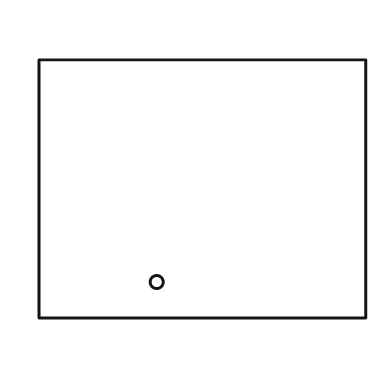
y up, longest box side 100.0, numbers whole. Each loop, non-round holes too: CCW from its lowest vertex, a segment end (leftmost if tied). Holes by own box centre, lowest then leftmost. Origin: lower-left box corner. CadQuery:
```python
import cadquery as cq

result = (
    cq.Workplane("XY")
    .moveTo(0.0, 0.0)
    .lineTo(100.0, 0.0)
    .lineTo(100.0, 79.0)
    .lineTo(0.0, 79.0)
    .close()
    .moveTo(36.0, 11.0)
    .circle(2.0)
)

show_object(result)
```